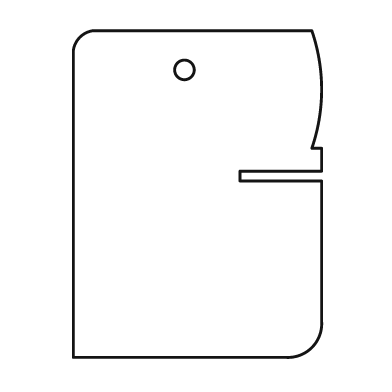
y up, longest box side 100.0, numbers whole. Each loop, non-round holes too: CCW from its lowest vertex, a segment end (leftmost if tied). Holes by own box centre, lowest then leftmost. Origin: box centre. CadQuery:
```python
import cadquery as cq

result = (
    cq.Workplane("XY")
    .moveTo(-38.0, -50.0)
    .lineTo(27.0, -50.0)
    .threePointArc((35.0, -47.0), (38.0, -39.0))
    .lineTo(38.0, 4.0)
    .lineTo(13.0, 4.0)
    .lineTo(13.0, 7.0)
    .lineTo(38.0, 7.0)
    .lineTo(38.0, 14.0)
    .lineTo(35.0, 14.0)
    .threePointArc((38.0, 32.0), (35.0, 50.0))
    .lineTo(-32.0, 50.0)
    .threePointArc((-36.0, 48.0), (-38.0, 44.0))
    .close()
    .moveTo(-4.0, 38.0)
    .circle(3.0)
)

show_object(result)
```